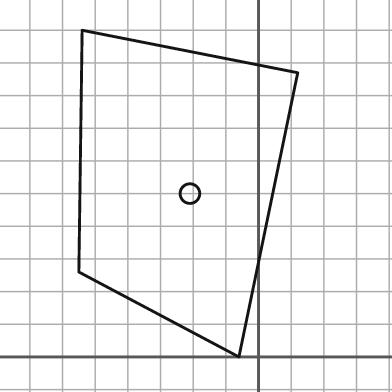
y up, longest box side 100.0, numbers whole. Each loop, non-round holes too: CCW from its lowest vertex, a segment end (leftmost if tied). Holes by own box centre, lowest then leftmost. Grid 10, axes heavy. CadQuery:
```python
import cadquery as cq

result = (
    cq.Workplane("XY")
    .moveTo(-6.0, 0.0)
    .lineTo(12.0, 87.0)
    .lineTo(-54.0, 100.0)
    .lineTo(-55.0, 26.0)
    .close()
    .moveTo(-21.0, 50.0)
    .circle(3.0)
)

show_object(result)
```